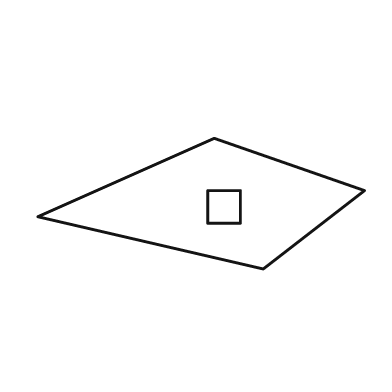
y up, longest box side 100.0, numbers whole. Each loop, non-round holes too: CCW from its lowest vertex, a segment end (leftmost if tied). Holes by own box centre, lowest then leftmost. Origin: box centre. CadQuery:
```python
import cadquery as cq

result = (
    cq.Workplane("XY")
    .moveTo(19.0, -20.0)
    .lineTo(50.0, 4.0)
    .lineTo(4.0, 20.0)
    .lineTo(-50.0, -4.0)
    .close()
    .moveTo(2.0, -6.0)
    .lineTo(12.0, -6.0)
    .lineTo(12.0, 4.0)
    .lineTo(2.0, 4.0)
    .close()
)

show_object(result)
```